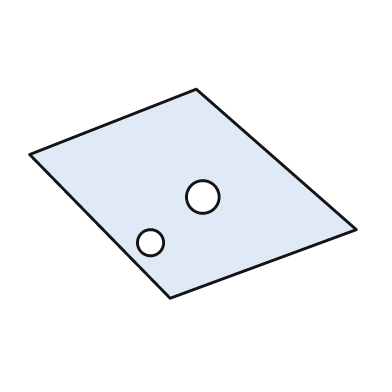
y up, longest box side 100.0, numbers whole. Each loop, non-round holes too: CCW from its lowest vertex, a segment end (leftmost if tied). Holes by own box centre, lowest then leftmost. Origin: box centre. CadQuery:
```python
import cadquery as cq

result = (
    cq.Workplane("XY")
    .moveTo(-7.0, -32.0)
    .lineTo(50.0, -11.0)
    .lineTo(1.0, 32.0)
    .lineTo(-50.0, 12.0)
    .close()
    .moveTo(-13.0, -15.0)
    .circle(4.0)
    .moveTo(3.0, -1.0)
    .circle(5.0)
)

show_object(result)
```